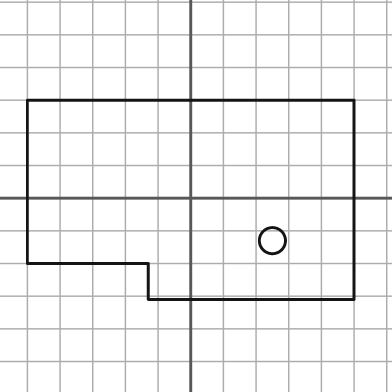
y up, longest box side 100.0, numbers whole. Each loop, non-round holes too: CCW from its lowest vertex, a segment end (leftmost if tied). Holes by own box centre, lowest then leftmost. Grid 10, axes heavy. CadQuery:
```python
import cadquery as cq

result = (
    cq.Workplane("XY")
    .moveTo(-13.0, -31.0)
    .lineTo(50.0, -31.0)
    .lineTo(50.0, 30.0)
    .lineTo(-50.0, 30.0)
    .lineTo(-50.0, -20.0)
    .lineTo(-13.0, -20.0)
    .close()
    .moveTo(25.0, -13.0)
    .circle(4.0)
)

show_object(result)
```